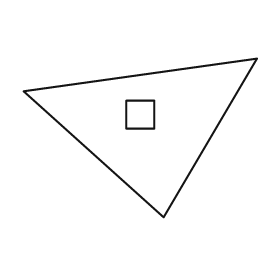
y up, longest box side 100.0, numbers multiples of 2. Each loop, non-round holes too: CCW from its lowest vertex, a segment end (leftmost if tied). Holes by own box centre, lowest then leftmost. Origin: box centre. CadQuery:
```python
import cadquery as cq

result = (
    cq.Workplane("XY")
    .moveTo(10.0, -34.0)
    .lineTo(50.0, 34.0)
    .lineTo(-50.0, 20.0)
    .close()
    .moveTo(-6.0, 4.0)
    .lineTo(6.0, 4.0)
    .lineTo(6.0, 16.0)
    .lineTo(-6.0, 16.0)
    .close()
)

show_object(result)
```